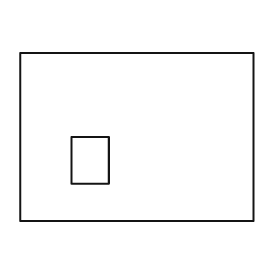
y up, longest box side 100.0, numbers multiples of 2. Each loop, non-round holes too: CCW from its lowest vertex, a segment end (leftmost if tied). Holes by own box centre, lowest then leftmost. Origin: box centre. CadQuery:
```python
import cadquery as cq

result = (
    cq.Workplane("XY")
    .moveTo(-50.0, -36.0)
    .lineTo(50.0, -36.0)
    .lineTo(50.0, 36.0)
    .lineTo(-50.0, 36.0)
    .close()
    .moveTo(-28.0, -20.0)
    .lineTo(-12.0, -20.0)
    .lineTo(-12.0, 0.0)
    .lineTo(-28.0, 0.0)
    .close()
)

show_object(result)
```